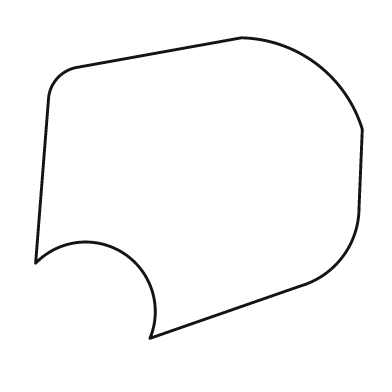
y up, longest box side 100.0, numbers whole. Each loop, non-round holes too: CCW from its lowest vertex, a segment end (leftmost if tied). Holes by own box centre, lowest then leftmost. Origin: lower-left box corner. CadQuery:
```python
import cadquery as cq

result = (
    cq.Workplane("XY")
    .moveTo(35.0, 0.0)
    .lineTo(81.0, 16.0)
    .threePointArc((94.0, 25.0), (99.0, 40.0))
    .lineTo(100.0, 64.0)
    .threePointArc((86.0, 84.0), (63.0, 92.0))
    .lineTo(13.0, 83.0)
    .threePointArc((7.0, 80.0), (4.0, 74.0))
    .lineTo(0.0, 23.0)
    .threePointArc((27.0, 26.0), (35.0, 0.0))
    .close()
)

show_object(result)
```